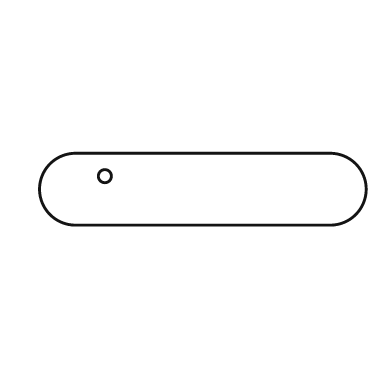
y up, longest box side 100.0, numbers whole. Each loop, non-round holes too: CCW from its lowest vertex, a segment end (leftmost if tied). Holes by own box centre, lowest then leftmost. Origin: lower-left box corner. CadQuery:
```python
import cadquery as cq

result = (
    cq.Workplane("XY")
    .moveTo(11.0, 0.0)
    .lineTo(89.0, 0.0)
    .threePointArc((100.0, 11.0), (89.0, 22.0))
    .lineTo(11.0, 22.0)
    .threePointArc((0.0, 11.0), (11.0, 0.0))
    .close()
    .moveTo(20.0, 15.0)
    .circle(2.0)
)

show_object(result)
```